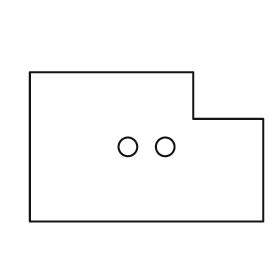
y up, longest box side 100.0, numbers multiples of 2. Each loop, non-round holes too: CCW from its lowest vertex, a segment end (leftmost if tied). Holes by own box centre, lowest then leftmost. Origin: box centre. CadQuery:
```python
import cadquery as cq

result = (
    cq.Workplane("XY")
    .moveTo(-50.0, -32.0)
    .lineTo(50.0, -32.0)
    .lineTo(50.0, 12.0)
    .lineTo(20.0, 12.0)
    .lineTo(20.0, 32.0)
    .lineTo(-50.0, 32.0)
    .close()
    .moveTo(-8.0, 0.0)
    .circle(4.0)
    .moveTo(8.0, 0.0)
    .circle(4.0)
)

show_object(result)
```